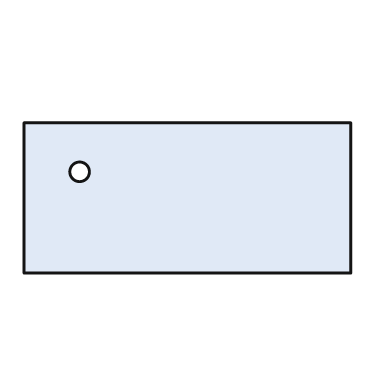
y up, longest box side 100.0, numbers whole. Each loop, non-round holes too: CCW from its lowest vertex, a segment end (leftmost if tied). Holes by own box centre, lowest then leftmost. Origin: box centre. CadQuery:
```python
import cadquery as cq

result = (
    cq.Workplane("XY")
    .moveTo(-50.0, -23.0)
    .lineTo(50.0, -23.0)
    .lineTo(50.0, 23.0)
    .lineTo(-50.0, 23.0)
    .close()
    .moveTo(-33.0, 8.0)
    .circle(3.0)
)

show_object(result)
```